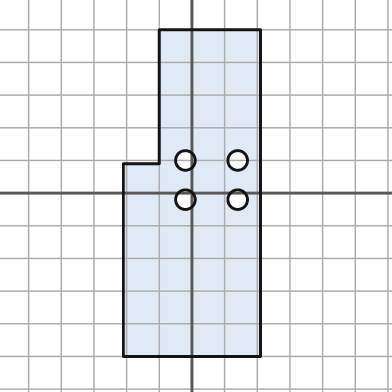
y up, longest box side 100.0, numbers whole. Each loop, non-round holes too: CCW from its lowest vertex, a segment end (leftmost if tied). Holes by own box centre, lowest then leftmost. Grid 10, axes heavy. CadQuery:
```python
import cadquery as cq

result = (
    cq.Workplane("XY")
    .moveTo(-21.0, -50.0)
    .lineTo(21.0, -50.0)
    .lineTo(21.0, 50.0)
    .lineTo(-10.0, 50.0)
    .lineTo(-10.0, 9.0)
    .lineTo(-21.0, 9.0)
    .close()
    .moveTo(-2.0, -2.0)
    .circle(3.0)
    .moveTo(14.0, -2.0)
    .circle(3.0)
    .moveTo(-2.0, 10.0)
    .circle(3.0)
    .moveTo(14.0, 10.0)
    .circle(3.0)
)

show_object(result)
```